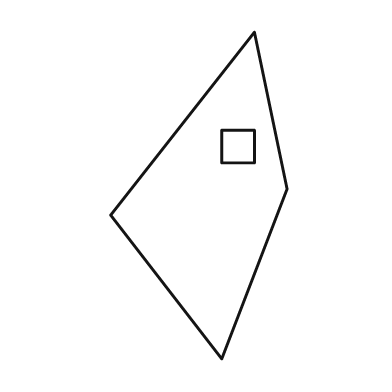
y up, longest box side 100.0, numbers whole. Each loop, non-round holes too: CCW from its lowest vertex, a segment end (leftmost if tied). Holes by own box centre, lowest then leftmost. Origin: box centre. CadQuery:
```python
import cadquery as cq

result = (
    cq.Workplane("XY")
    .moveTo(7.0, -50.0)
    .lineTo(27.0, 2.0)
    .lineTo(17.0, 50.0)
    .lineTo(-27.0, -6.0)
    .close()
    .moveTo(7.0, 10.0)
    .lineTo(17.0, 10.0)
    .lineTo(17.0, 20.0)
    .lineTo(7.0, 20.0)
    .close()
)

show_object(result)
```